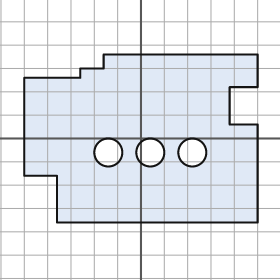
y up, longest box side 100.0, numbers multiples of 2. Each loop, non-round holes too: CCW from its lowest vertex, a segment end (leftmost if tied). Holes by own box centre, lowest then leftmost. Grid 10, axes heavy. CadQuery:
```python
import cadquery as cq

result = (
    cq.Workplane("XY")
    .moveTo(-36.0, -36.0)
    .lineTo(50.0, -36.0)
    .lineTo(50.0, 6.0)
    .lineTo(38.0, 6.0)
    .lineTo(38.0, 22.0)
    .lineTo(50.0, 22.0)
    .lineTo(50.0, 36.0)
    .lineTo(-16.0, 36.0)
    .lineTo(-16.0, 30.0)
    .lineTo(-26.0, 30.0)
    .lineTo(-26.0, 26.0)
    .lineTo(-50.0, 26.0)
    .lineTo(-50.0, -16.0)
    .lineTo(-36.0, -16.0)
    .close()
    .moveTo(-14.0, -6.0)
    .circle(6.0)
    .moveTo(4.0, -6.0)
    .circle(6.0)
    .moveTo(22.0, -6.0)
    .circle(6.0)
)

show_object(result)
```